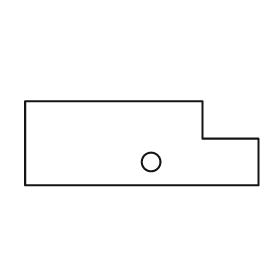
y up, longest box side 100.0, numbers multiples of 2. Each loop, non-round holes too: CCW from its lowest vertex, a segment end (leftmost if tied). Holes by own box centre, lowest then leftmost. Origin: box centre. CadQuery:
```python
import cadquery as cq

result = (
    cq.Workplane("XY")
    .moveTo(-50.0, -18.0)
    .lineTo(50.0, -18.0)
    .lineTo(50.0, 2.0)
    .lineTo(26.0, 2.0)
    .lineTo(26.0, 18.0)
    .lineTo(-50.0, 18.0)
    .close()
    .moveTo(4.0, -8.0)
    .circle(4.0)
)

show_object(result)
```